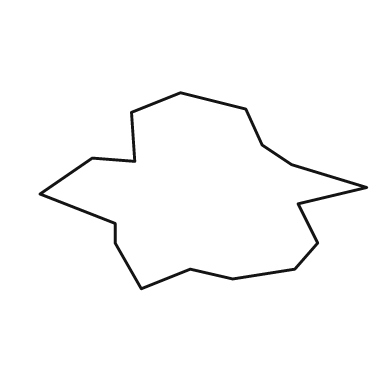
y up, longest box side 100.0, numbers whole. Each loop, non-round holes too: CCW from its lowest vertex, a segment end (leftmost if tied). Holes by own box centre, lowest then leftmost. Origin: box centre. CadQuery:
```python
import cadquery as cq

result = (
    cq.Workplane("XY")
    .moveTo(-19.0, -30.0)
    .lineTo(-4.0, -24.0)
    .lineTo(9.0, -27.0)
    .lineTo(28.0, -24.0)
    .lineTo(35.0, -16.0)
    .lineTo(29.0, -4.0)
    .lineTo(50.0, 1.0)
    .lineTo(27.0, 8.0)
    .lineTo(18.0, 14.0)
    .lineTo(13.0, 25.0)
    .lineTo(-7.0, 30.0)
    .lineTo(-22.0, 24.0)
    .lineTo(-21.0, 9.0)
    .lineTo(-34.0, 10.0)
    .lineTo(-50.0, -1.0)
    .lineTo(-27.0, -10.0)
    .lineTo(-27.0, -16.0)
    .close()
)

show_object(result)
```